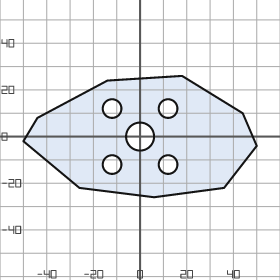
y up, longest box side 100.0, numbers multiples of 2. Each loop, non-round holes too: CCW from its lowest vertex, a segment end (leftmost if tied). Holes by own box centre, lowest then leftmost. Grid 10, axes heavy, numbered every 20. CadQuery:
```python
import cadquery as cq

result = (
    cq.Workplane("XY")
    .moveTo(6.0, -26.0)
    .lineTo(36.0, -22.0)
    .lineTo(50.0, -4.0)
    .lineTo(44.0, 10.0)
    .lineTo(18.0, 26.0)
    .lineTo(-14.0, 24.0)
    .lineTo(-44.0, 8.0)
    .lineTo(-50.0, -2.0)
    .lineTo(-26.0, -22.0)
    .close()
    .moveTo(-12.0, -12.0)
    .circle(4.0)
    .moveTo(12.0, -12.0)
    .circle(4.0)
    .moveTo(0.0, 0.0)
    .circle(6.0)
    .moveTo(-12.0, 12.0)
    .circle(4.0)
    .moveTo(12.0, 12.0)
    .circle(4.0)
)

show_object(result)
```